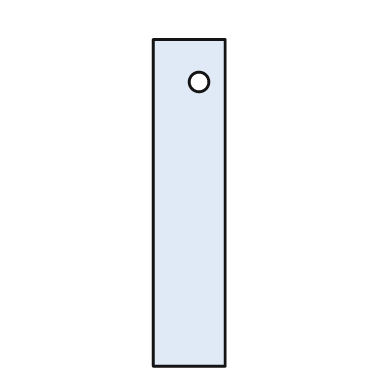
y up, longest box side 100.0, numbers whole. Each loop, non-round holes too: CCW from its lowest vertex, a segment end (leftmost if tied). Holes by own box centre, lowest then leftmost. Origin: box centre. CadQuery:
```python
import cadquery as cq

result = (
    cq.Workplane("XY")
    .moveTo(-11.0, -50.0)
    .lineTo(11.0, -50.0)
    .lineTo(11.0, 50.0)
    .lineTo(-11.0, 50.0)
    .close()
    .moveTo(3.0, 37.0)
    .circle(3.0)
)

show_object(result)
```